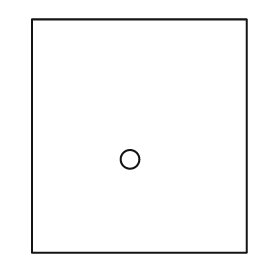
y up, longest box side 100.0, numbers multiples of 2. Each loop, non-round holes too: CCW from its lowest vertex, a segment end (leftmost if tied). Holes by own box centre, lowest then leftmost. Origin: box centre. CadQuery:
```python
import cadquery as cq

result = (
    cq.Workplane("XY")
    .moveTo(-46.0, -50.0)
    .lineTo(46.0, -50.0)
    .lineTo(46.0, 50.0)
    .lineTo(-46.0, 50.0)
    .close()
    .moveTo(-4.0, -10.0)
    .circle(4.0)
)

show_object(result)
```